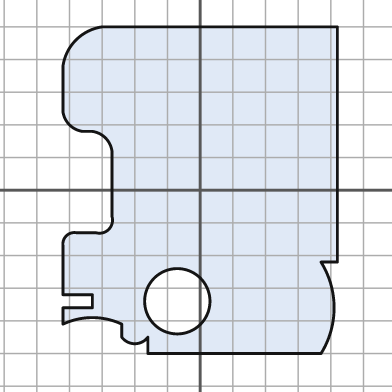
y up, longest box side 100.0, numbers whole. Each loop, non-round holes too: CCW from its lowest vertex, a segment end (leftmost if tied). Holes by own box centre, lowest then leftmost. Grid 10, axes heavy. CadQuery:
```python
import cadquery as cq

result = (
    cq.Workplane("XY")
    .moveTo(-16.0, -50.0)
    .lineTo(37.0, -50.0)
    .threePointArc((41.0, -36.0), (37.0, -22.0))
    .lineTo(42.0, -22.0)
    .lineTo(42.0, 50.0)
    .lineTo(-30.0, 50.0)
    .threePointArc((-38.0, 46.0), (-42.0, 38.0))
    .lineTo(-42.0, 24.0)
    .threePointArc((-40.0, 20.0), (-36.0, 18.0))
    .lineTo(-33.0, 18.0)
    .threePointArc((-29.0, 16.0), (-27.0, 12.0))
    .lineTo(-27.0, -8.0)
    .threePointArc((-28.0, -12.0), (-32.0, -13.0))
    .lineTo(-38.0, -13.0)
    .threePointArc((-41.0, -14.0), (-42.0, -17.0))
    .lineTo(-42.0, -32.0)
    .lineTo(-33.0, -32.0)
    .lineTo(-33.0, -36.0)
    .lineTo(-42.0, -36.0)
    .lineTo(-42.0, -41.0)
    .threePointArc((-33.0, -39.0), (-24.0, -41.0))
    .lineTo(-24.0, -45.0)
    .threePointArc((-20.0, -47.0), (-16.0, -45.0))
    .close()
    .moveTo(-7.0, -34.0)
    .circle(10.0)
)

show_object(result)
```